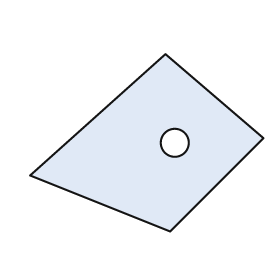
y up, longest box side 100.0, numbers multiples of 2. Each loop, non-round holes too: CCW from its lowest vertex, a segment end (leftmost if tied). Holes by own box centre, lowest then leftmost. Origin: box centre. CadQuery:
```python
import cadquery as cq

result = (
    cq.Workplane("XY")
    .moveTo(10.0, -38.0)
    .lineTo(50.0, 2.0)
    .lineTo(8.0, 38.0)
    .lineTo(-50.0, -14.0)
    .close()
    .moveTo(12.0, 0.0)
    .circle(6.0)
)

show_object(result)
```